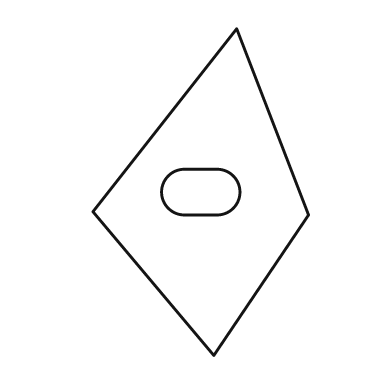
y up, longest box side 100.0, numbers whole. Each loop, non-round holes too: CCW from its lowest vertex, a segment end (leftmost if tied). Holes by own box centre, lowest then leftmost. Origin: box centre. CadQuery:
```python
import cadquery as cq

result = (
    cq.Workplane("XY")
    .moveTo(4.0, -50.0)
    .lineTo(33.0, -7.0)
    .lineTo(11.0, 50.0)
    .lineTo(-33.0, -6.0)
    .close()
    .moveTo(-5.0, -7.0)
    .lineTo(5.0, -7.0)
    .threePointArc((12.0, 0.0), (5.0, 7.0))
    .lineTo(-5.0, 7.0)
    .threePointArc((-12.0, 0.0), (-5.0, -7.0))
    .close()
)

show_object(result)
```